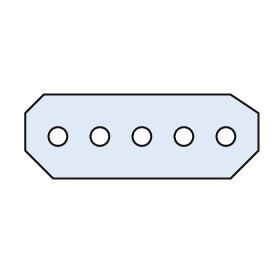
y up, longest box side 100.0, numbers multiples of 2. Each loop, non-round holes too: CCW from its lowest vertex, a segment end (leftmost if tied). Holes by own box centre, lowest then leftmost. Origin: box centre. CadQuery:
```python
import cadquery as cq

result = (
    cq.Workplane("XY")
    .moveTo(-38.0, -18.0)
    .lineTo(38.0, -18.0)
    .lineTo(50.0, -6.0)
    .lineTo(50.0, 10.0)
    .lineTo(38.0, 18.0)
    .lineTo(-42.0, 18.0)
    .lineTo(-50.0, 10.0)
    .lineTo(-50.0, -6.0)
    .close()
    .moveTo(-36.0, 0.0)
    .circle(4.0)
    .moveTo(-18.0, 0.0)
    .circle(4.0)
    .moveTo(0.0, 0.0)
    .circle(4.0)
    .moveTo(18.0, 0.0)
    .circle(4.0)
    .moveTo(36.0, 0.0)
    .circle(4.0)
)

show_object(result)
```